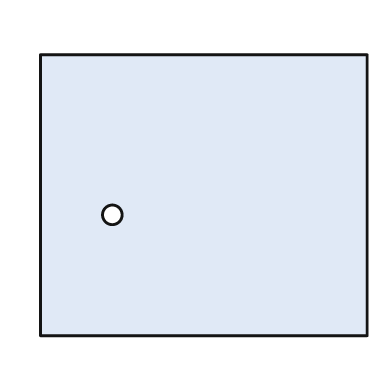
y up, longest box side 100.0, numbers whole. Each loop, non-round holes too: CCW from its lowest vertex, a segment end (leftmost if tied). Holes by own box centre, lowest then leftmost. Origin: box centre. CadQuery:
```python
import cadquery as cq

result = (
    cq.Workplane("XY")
    .moveTo(-50.0, -43.0)
    .lineTo(50.0, -43.0)
    .lineTo(50.0, 43.0)
    .lineTo(-50.0, 43.0)
    .close()
    .moveTo(-28.0, -6.0)
    .circle(3.0)
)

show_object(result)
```